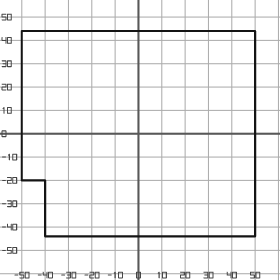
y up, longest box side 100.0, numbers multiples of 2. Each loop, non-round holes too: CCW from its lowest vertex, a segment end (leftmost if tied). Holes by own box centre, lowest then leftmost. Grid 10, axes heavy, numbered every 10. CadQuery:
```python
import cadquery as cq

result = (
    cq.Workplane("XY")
    .moveTo(-40.0, -44.0)
    .lineTo(50.0, -44.0)
    .lineTo(50.0, 44.0)
    .lineTo(-50.0, 44.0)
    .lineTo(-50.0, -20.0)
    .lineTo(-40.0, -20.0)
    .close()
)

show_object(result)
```